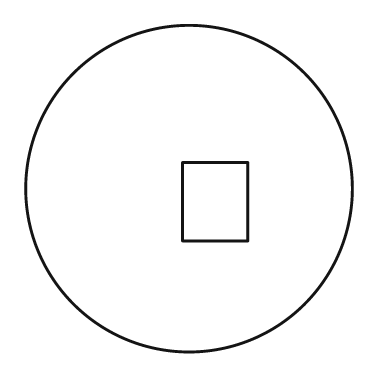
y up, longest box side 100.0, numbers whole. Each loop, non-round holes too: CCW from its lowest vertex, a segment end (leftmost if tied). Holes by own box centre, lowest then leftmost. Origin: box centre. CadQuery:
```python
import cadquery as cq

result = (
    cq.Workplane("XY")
    .moveTo(0.0, 0.0)
    .circle(50.0)
    .moveTo(-2.0, -16.0)
    .lineTo(18.0, -16.0)
    .lineTo(18.0, 8.0)
    .lineTo(-2.0, 8.0)
    .close()
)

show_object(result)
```